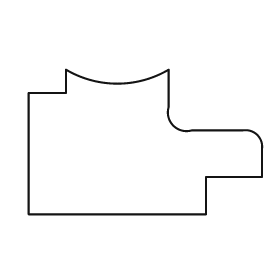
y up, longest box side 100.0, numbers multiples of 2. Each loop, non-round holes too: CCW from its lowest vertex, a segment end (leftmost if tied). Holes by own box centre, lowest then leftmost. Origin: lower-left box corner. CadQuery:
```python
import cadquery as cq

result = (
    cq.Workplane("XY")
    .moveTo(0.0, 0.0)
    .lineTo(76.0, 0.0)
    .lineTo(76.0, 16.0)
    .lineTo(100.0, 16.0)
    .lineTo(100.0, 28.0)
    .threePointArc((98.0, 34.0), (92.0, 36.0))
    .lineTo(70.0, 36.0)
    .threePointArc((62.0, 38.0), (60.0, 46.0))
    .lineTo(60.0, 62.0)
    .threePointArc((38.0, 56.0), (16.0, 62.0))
    .lineTo(16.0, 52.0)
    .lineTo(0.0, 52.0)
    .close()
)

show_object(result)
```